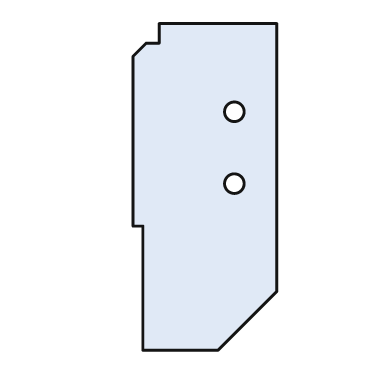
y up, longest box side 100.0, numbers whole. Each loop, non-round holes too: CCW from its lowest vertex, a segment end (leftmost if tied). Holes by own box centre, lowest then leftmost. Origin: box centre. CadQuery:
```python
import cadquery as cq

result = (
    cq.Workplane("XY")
    .moveTo(-19.0, -50.0)
    .lineTo(4.0, -50.0)
    .lineTo(22.0, -32.0)
    .lineTo(22.0, 50.0)
    .lineTo(-14.0, 50.0)
    .lineTo(-14.0, 44.0)
    .lineTo(-18.0, 44.0)
    .lineTo(-22.0, 40.0)
    .lineTo(-22.0, -12.0)
    .lineTo(-19.0, -12.0)
    .close()
    .moveTo(9.0, 1.0)
    .circle(3.0)
    .moveTo(9.0, 23.0)
    .circle(3.0)
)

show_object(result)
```